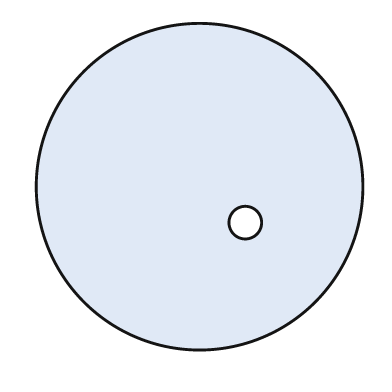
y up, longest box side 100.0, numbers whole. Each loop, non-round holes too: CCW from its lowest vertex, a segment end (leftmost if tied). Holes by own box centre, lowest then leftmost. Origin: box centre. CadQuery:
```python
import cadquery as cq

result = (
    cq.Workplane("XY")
    .moveTo(0.0, 0.0)
    .circle(50.0)
    .moveTo(14.0, -11.0)
    .circle(5.0)
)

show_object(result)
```